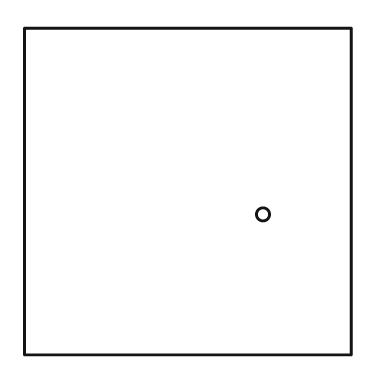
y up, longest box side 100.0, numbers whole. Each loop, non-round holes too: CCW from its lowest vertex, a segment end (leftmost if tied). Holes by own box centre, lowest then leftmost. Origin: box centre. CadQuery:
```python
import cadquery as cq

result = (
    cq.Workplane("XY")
    .moveTo(-50.0, -50.0)
    .lineTo(50.0, -50.0)
    .lineTo(50.0, 50.0)
    .lineTo(-50.0, 50.0)
    .close()
    .moveTo(23.0, -7.0)
    .circle(2.0)
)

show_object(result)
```